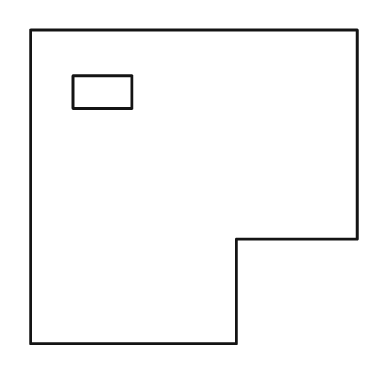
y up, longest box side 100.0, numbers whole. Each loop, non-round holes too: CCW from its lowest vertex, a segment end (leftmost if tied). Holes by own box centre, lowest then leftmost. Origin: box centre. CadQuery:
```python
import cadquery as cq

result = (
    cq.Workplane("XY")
    .moveTo(-50.0, -48.0)
    .lineTo(13.0, -48.0)
    .lineTo(13.0, -16.0)
    .lineTo(50.0, -16.0)
    .lineTo(50.0, 48.0)
    .lineTo(-50.0, 48.0)
    .close()
    .moveTo(-37.0, 24.0)
    .lineTo(-19.0, 24.0)
    .lineTo(-19.0, 34.0)
    .lineTo(-37.0, 34.0)
    .close()
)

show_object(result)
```